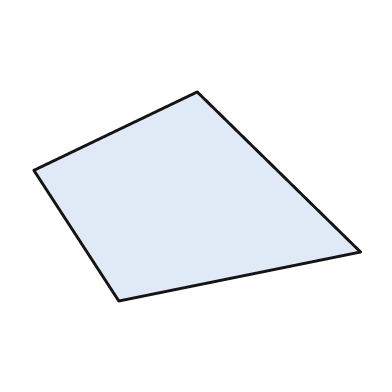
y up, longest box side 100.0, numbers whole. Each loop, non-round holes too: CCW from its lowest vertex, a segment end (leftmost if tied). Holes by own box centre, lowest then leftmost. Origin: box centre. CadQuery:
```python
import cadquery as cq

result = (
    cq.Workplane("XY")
    .moveTo(-24.0, -32.0)
    .lineTo(50.0, -17.0)
    .lineTo(0.0, 32.0)
    .lineTo(-50.0, 8.0)
    .close()
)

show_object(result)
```